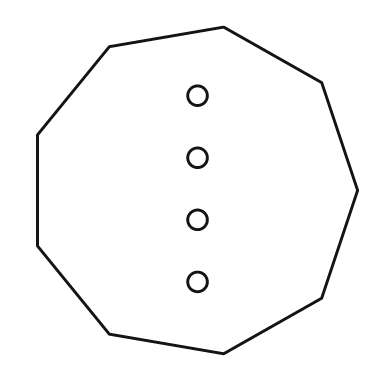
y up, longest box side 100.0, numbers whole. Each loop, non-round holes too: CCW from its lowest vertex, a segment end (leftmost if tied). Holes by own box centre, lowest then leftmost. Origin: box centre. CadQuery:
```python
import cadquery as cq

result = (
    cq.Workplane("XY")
    .moveTo(8.0, -50.0)
    .lineTo(38.0, -33.0)
    .lineTo(49.0, 0.0)
    .lineTo(38.0, 33.0)
    .lineTo(8.0, 50.0)
    .lineTo(-27.0, 44.0)
    .lineTo(-49.0, 17.0)
    .lineTo(-49.0, -17.0)
    .lineTo(-27.0, -44.0)
    .close()
    .moveTo(0.0, -28.0)
    .circle(3.0)
    .moveTo(0.0, -9.0)
    .circle(3.0)
    .moveTo(0.0, 10.0)
    .circle(3.0)
    .moveTo(0.0, 29.0)
    .circle(3.0)
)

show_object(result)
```